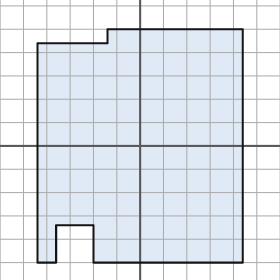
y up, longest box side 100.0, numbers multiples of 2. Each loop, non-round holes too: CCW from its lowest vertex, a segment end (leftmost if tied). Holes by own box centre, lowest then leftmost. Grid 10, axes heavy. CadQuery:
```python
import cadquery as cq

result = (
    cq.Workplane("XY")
    .moveTo(-44.0, -50.0)
    .lineTo(-36.0, -50.0)
    .lineTo(-36.0, -34.0)
    .lineTo(-20.0, -34.0)
    .lineTo(-20.0, -50.0)
    .lineTo(44.0, -50.0)
    .lineTo(44.0, 50.0)
    .lineTo(-14.0, 50.0)
    .lineTo(-14.0, 44.0)
    .lineTo(-44.0, 44.0)
    .close()
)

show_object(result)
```